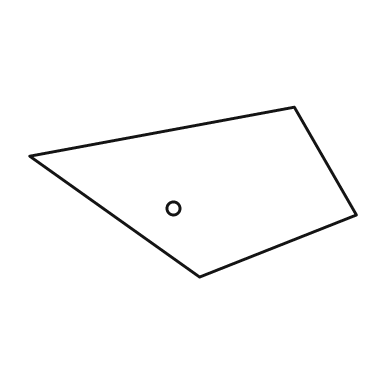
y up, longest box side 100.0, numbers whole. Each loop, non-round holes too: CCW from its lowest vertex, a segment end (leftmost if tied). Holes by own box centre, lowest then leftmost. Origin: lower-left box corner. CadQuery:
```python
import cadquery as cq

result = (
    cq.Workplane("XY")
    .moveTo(52.0, 0.0)
    .lineTo(100.0, 19.0)
    .lineTo(81.0, 52.0)
    .lineTo(0.0, 37.0)
    .close()
    .moveTo(44.0, 21.0)
    .circle(2.0)
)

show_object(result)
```